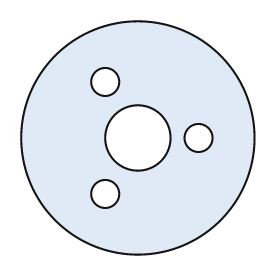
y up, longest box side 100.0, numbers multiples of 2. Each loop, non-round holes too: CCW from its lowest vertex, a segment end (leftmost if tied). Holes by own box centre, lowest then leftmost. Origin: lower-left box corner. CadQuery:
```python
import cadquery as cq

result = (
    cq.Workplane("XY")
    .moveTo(50.0, 50.0)
    .circle(50.0)
    .moveTo(36.0, 26.0)
    .circle(6.0)
    .moveTo(50.0, 50.0)
    .circle(14.0)
    .moveTo(76.0, 50.0)
    .circle(6.0)
    .moveTo(36.0, 74.0)
    .circle(6.0)
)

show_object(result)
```